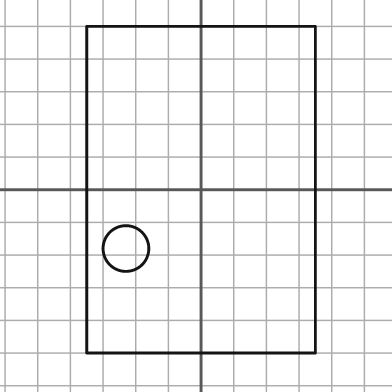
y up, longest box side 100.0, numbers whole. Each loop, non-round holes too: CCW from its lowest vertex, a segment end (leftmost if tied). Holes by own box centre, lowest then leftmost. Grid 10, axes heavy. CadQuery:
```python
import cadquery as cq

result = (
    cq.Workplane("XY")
    .moveTo(-35.0, -50.0)
    .lineTo(35.0, -50.0)
    .lineTo(35.0, 50.0)
    .lineTo(-35.0, 50.0)
    .close()
    .moveTo(-23.0, -18.0)
    .circle(7.0)
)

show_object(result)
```